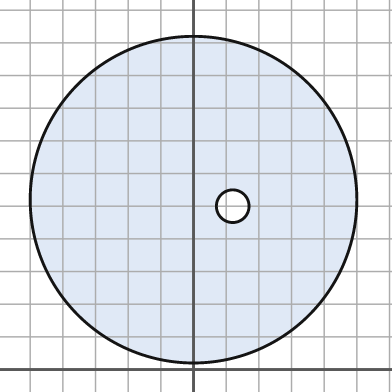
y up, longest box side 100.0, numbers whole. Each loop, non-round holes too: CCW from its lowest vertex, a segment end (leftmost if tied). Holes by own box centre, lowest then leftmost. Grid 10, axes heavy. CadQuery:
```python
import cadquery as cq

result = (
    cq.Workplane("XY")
    .moveTo(0.0, 52.0)
    .circle(50.0)
    .moveTo(12.0, 50.0)
    .circle(5.0)
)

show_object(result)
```